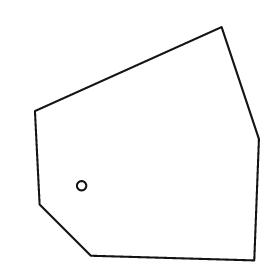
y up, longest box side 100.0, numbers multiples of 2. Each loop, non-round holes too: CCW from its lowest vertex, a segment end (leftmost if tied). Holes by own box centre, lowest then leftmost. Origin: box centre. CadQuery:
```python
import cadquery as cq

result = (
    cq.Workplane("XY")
    .moveTo(46.0, -50.0)
    .lineTo(48.0, 2.0)
    .lineTo(32.0, 50.0)
    .lineTo(-48.0, 14.0)
    .lineTo(-46.0, -26.0)
    .lineTo(-24.0, -48.0)
    .close()
    .moveTo(-28.0, -18.0)
    .circle(2.0)
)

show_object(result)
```